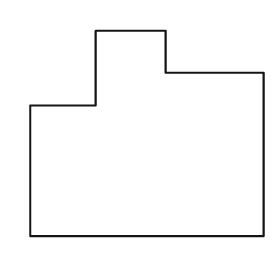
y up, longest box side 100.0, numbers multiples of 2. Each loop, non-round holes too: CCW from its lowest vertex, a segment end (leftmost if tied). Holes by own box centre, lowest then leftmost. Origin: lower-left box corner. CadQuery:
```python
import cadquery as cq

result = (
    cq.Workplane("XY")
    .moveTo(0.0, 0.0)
    .lineTo(100.0, 0.0)
    .lineTo(100.0, 70.0)
    .lineTo(58.0, 70.0)
    .lineTo(58.0, 88.0)
    .lineTo(28.0, 88.0)
    .lineTo(28.0, 56.0)
    .lineTo(0.0, 56.0)
    .close()
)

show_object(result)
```